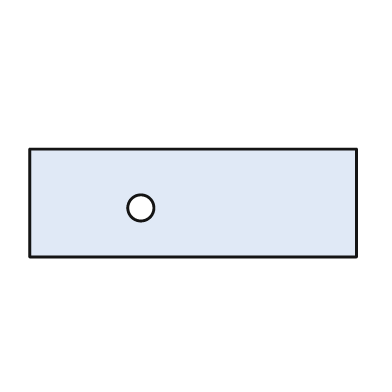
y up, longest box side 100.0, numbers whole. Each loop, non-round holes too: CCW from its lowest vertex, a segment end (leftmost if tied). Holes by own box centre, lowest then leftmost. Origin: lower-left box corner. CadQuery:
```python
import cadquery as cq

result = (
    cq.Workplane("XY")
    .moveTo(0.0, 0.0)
    .lineTo(100.0, 0.0)
    .lineTo(100.0, 33.0)
    .lineTo(0.0, 33.0)
    .close()
    .moveTo(34.0, 15.0)
    .circle(4.0)
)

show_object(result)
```